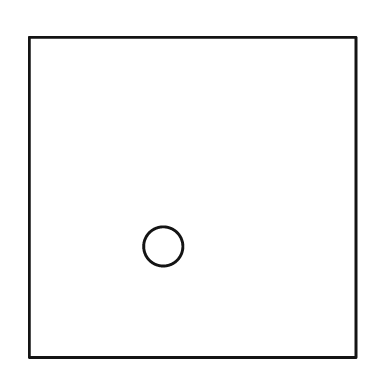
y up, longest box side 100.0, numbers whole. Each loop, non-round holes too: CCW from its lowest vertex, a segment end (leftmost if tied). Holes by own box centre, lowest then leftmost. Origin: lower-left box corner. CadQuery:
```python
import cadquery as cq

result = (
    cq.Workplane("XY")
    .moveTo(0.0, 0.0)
    .lineTo(100.0, 0.0)
    .lineTo(100.0, 98.0)
    .lineTo(0.0, 98.0)
    .close()
    .moveTo(41.0, 34.0)
    .circle(6.0)
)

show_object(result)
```